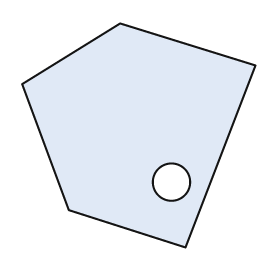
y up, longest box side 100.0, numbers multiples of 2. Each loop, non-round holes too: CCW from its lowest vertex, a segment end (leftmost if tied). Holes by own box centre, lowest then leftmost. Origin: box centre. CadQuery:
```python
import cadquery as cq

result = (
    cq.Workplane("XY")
    .moveTo(20.0, -48.0)
    .lineTo(50.0, 30.0)
    .lineTo(-8.0, 48.0)
    .lineTo(-50.0, 22.0)
    .lineTo(-30.0, -32.0)
    .close()
    .moveTo(14.0, -20.0)
    .circle(8.0)
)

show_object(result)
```